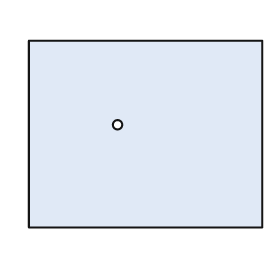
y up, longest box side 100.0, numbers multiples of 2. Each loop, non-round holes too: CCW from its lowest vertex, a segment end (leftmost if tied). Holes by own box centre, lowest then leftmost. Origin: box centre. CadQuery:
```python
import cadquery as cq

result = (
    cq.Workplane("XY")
    .moveTo(-50.0, -40.0)
    .lineTo(50.0, -40.0)
    .lineTo(50.0, 40.0)
    .lineTo(-50.0, 40.0)
    .close()
    .moveTo(-12.0, 4.0)
    .circle(2.0)
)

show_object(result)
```